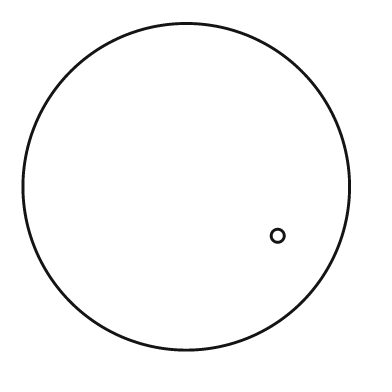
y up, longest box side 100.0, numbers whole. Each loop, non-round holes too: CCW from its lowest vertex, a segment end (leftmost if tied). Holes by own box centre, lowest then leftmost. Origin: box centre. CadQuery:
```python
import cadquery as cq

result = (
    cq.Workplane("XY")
    .moveTo(0.0, 0.0)
    .circle(50.0)
    .moveTo(28.0, -15.0)
    .circle(2.0)
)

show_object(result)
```